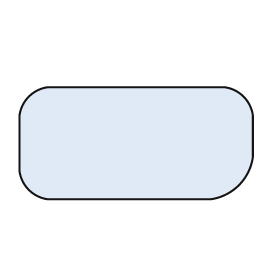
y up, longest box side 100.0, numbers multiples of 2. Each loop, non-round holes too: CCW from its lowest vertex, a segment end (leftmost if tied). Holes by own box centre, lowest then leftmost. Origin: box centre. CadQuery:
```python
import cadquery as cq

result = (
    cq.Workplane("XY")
    .moveTo(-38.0, -24.0)
    .lineTo(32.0, -24.0)
    .threePointArc((44.0, -18.0), (50.0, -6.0))
    .lineTo(50.0, 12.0)
    .threePointArc((46.0, 20.0), (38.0, 24.0))
    .lineTo(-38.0, 24.0)
    .threePointArc((-46.0, 20.0), (-50.0, 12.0))
    .lineTo(-50.0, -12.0)
    .threePointArc((-46.0, -20.0), (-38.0, -24.0))
    .close()
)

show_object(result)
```